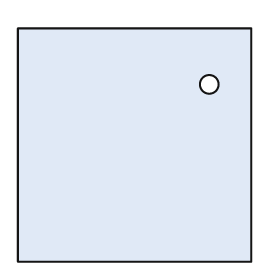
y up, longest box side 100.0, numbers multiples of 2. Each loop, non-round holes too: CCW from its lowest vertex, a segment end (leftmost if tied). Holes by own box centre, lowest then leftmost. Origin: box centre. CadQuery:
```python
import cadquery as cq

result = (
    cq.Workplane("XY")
    .moveTo(-50.0, -50.0)
    .lineTo(50.0, -50.0)
    .lineTo(50.0, 50.0)
    .lineTo(-50.0, 50.0)
    .close()
    .moveTo(32.0, 26.0)
    .circle(4.0)
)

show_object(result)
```